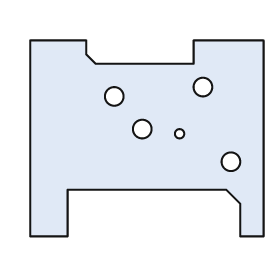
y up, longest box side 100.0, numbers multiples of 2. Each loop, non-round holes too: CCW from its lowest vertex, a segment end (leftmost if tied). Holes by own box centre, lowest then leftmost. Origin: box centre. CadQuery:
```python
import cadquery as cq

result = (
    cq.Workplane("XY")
    .moveTo(-50.0, -42.0)
    .lineTo(-34.0, -42.0)
    .lineTo(-34.0, -22.0)
    .lineTo(34.0, -22.0)
    .lineTo(40.0, -28.0)
    .lineTo(40.0, -42.0)
    .lineTo(50.0, -42.0)
    .lineTo(50.0, 42.0)
    .lineTo(20.0, 42.0)
    .lineTo(20.0, 32.0)
    .lineTo(-22.0, 32.0)
    .lineTo(-26.0, 36.0)
    .lineTo(-26.0, 42.0)
    .lineTo(-50.0, 42.0)
    .close()
    .moveTo(36.0, -10.0)
    .circle(4.0)
    .moveTo(14.0, 2.0)
    .circle(2.0)
    .moveTo(-2.0, 4.0)
    .circle(4.0)
    .moveTo(-14.0, 18.0)
    .circle(4.0)
    .moveTo(24.0, 22.0)
    .circle(4.0)
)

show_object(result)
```